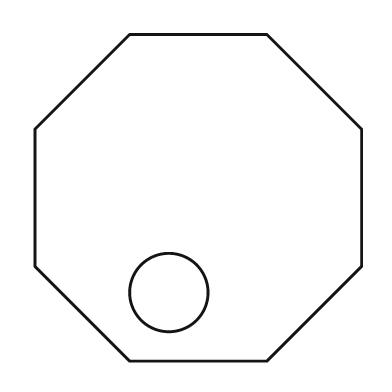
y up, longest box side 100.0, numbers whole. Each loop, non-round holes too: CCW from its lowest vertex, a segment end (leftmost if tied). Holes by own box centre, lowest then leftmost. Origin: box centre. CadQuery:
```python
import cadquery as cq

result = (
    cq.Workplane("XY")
    .moveTo(-21.0, -50.0)
    .lineTo(21.0, -50.0)
    .lineTo(50.0, -21.0)
    .lineTo(50.0, 21.0)
    .lineTo(21.0, 50.0)
    .lineTo(-21.0, 50.0)
    .lineTo(-50.0, 21.0)
    .lineTo(-50.0, -21.0)
    .close()
    .moveTo(-9.0, -29.0)
    .circle(12.0)
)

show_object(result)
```